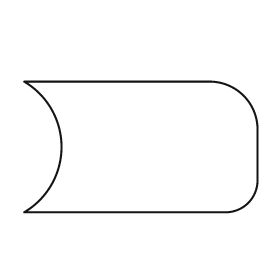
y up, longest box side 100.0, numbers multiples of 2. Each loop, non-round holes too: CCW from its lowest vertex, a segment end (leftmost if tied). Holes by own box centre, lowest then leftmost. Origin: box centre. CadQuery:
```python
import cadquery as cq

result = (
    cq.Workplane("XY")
    .moveTo(-50.0, -28.0)
    .lineTo(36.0, -28.0)
    .threePointArc((46.0, -24.0), (50.0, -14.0))
    .lineTo(50.0, 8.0)
    .threePointArc((44.0, 22.0), (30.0, 28.0))
    .lineTo(-50.0, 28.0)
    .threePointArc((-34.0, 0.0), (-50.0, -28.0))
    .close()
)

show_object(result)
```